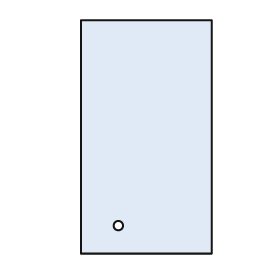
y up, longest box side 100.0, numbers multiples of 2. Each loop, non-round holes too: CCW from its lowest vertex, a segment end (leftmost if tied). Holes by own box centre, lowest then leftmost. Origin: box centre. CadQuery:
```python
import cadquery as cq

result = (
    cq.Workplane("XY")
    .moveTo(-28.0, -50.0)
    .lineTo(28.0, -50.0)
    .lineTo(28.0, 50.0)
    .lineTo(-28.0, 50.0)
    .close()
    .moveTo(-12.0, -38.0)
    .circle(2.0)
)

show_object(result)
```